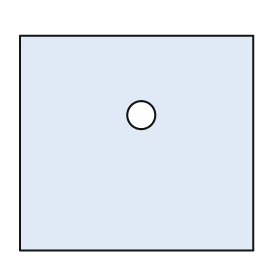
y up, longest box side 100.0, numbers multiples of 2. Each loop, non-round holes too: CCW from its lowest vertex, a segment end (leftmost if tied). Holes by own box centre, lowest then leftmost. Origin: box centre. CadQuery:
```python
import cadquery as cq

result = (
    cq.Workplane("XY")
    .moveTo(-50.0, -46.0)
    .lineTo(50.0, -46.0)
    .lineTo(50.0, 46.0)
    .lineTo(-50.0, 46.0)
    .close()
    .moveTo(2.0, 12.0)
    .circle(6.0)
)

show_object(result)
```